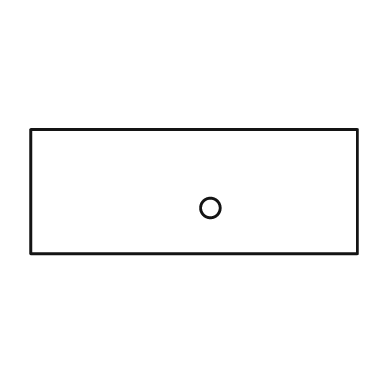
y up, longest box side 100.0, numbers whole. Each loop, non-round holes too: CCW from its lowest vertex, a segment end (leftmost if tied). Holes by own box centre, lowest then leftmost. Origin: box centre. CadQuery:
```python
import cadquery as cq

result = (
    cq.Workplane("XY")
    .moveTo(-50.0, -19.0)
    .lineTo(50.0, -19.0)
    .lineTo(50.0, 19.0)
    .lineTo(-50.0, 19.0)
    .close()
    .moveTo(5.0, -5.0)
    .circle(3.0)
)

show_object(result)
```